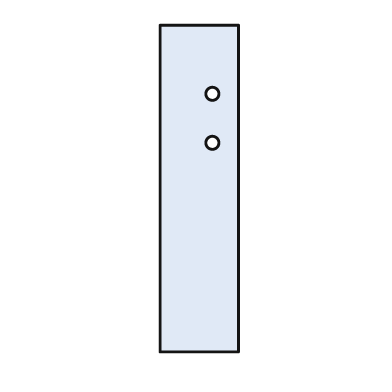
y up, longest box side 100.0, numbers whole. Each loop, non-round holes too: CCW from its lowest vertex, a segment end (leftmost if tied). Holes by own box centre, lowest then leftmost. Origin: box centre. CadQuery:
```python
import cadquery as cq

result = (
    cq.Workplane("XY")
    .moveTo(-12.0, -50.0)
    .lineTo(12.0, -50.0)
    .lineTo(12.0, 50.0)
    .lineTo(-12.0, 50.0)
    .close()
    .moveTo(4.0, 14.0)
    .circle(2.0)
    .moveTo(4.0, 29.0)
    .circle(2.0)
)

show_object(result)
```